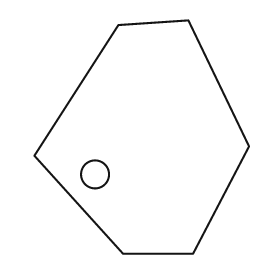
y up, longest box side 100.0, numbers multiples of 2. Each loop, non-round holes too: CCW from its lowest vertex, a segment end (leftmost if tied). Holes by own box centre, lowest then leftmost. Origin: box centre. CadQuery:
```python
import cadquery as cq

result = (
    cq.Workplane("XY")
    .moveTo(-8.0, -50.0)
    .lineTo(22.0, -50.0)
    .lineTo(46.0, -4.0)
    .lineTo(20.0, 50.0)
    .lineTo(-10.0, 48.0)
    .lineTo(-46.0, -8.0)
    .close()
    .moveTo(-20.0, -16.0)
    .circle(6.0)
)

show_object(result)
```